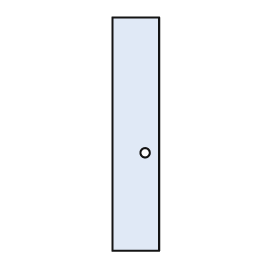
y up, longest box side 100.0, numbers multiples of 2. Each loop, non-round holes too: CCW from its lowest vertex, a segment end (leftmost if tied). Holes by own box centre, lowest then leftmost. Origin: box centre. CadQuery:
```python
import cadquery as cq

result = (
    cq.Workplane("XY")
    .moveTo(-10.0, -50.0)
    .lineTo(10.0, -50.0)
    .lineTo(10.0, 50.0)
    .lineTo(-10.0, 50.0)
    .close()
    .moveTo(4.0, -8.0)
    .circle(2.0)
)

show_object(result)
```